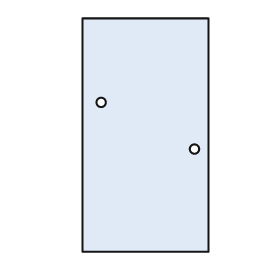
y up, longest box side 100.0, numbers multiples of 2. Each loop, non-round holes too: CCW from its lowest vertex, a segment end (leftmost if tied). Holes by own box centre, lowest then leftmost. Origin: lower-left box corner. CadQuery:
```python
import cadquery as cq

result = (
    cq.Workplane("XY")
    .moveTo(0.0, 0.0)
    .lineTo(54.0, 0.0)
    .lineTo(54.0, 100.0)
    .lineTo(0.0, 100.0)
    .close()
    .moveTo(48.0, 44.0)
    .circle(2.0)
    .moveTo(8.0, 64.0)
    .circle(2.0)
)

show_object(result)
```